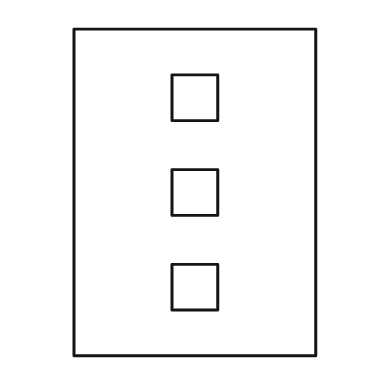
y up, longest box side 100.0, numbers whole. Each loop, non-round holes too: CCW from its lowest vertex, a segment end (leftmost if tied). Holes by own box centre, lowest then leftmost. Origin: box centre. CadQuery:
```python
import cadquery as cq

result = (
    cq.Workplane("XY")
    .moveTo(-37.0, -50.0)
    .lineTo(37.0, -50.0)
    .lineTo(37.0, 50.0)
    .lineTo(-37.0, 50.0)
    .close()
    .moveTo(-7.0, -36.0)
    .lineTo(7.0, -36.0)
    .lineTo(7.0, -22.0)
    .lineTo(-7.0, -22.0)
    .close()
    .moveTo(-7.0, -7.0)
    .lineTo(7.0, -7.0)
    .lineTo(7.0, 7.0)
    .lineTo(-7.0, 7.0)
    .close()
    .moveTo(-7.0, 22.0)
    .lineTo(7.0, 22.0)
    .lineTo(7.0, 36.0)
    .lineTo(-7.0, 36.0)
    .close()
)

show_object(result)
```